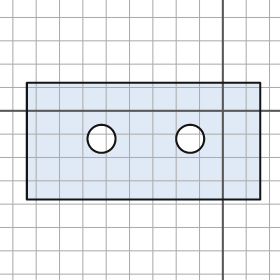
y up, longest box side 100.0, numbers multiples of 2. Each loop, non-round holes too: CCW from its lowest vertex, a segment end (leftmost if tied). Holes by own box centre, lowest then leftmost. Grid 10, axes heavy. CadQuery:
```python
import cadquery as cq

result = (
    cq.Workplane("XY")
    .moveTo(-84.0, -38.0)
    .lineTo(16.0, -38.0)
    .lineTo(16.0, 12.0)
    .lineTo(-84.0, 12.0)
    .close()
    .moveTo(-52.0, -12.0)
    .circle(6.0)
    .moveTo(-14.0, -12.0)
    .circle(6.0)
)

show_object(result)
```